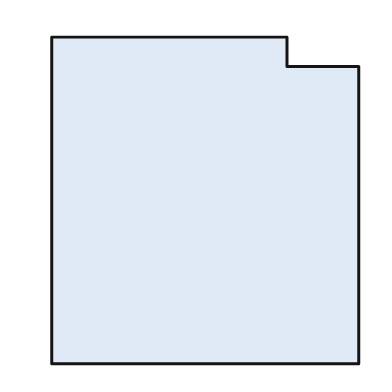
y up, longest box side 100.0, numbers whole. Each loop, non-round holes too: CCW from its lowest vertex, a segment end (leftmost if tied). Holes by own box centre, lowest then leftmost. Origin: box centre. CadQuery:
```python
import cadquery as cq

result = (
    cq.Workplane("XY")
    .moveTo(-47.0, -50.0)
    .lineTo(47.0, -50.0)
    .lineTo(47.0, 41.0)
    .lineTo(25.0, 41.0)
    .lineTo(25.0, 50.0)
    .lineTo(-47.0, 50.0)
    .close()
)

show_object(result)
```